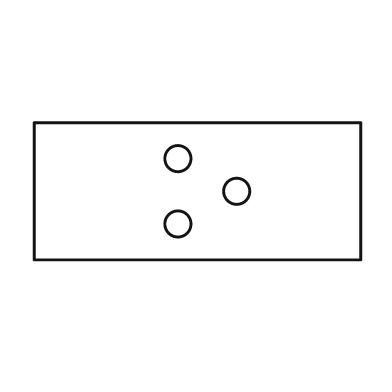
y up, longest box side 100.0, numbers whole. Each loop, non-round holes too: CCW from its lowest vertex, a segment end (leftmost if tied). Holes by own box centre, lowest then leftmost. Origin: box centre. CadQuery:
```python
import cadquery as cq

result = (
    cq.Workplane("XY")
    .moveTo(-50.0, -21.0)
    .lineTo(50.0, -21.0)
    .lineTo(50.0, 21.0)
    .lineTo(-50.0, 21.0)
    .close()
    .moveTo(-6.0, -10.0)
    .circle(4.0)
    .moveTo(12.0, 0.0)
    .circle(4.0)
    .moveTo(-6.0, 10.0)
    .circle(4.0)
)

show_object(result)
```